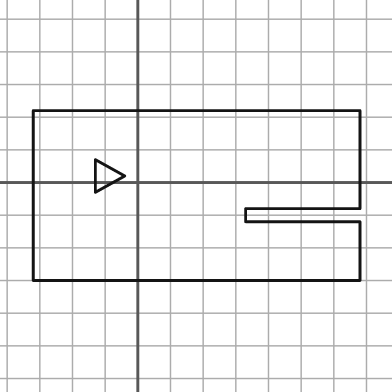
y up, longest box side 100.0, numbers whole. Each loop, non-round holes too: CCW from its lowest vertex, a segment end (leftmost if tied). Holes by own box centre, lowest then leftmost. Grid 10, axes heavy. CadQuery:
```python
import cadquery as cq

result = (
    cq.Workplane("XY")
    .moveTo(-32.0, -30.0)
    .lineTo(68.0, -30.0)
    .lineTo(68.0, -12.0)
    .lineTo(33.0, -12.0)
    .lineTo(33.0, -8.0)
    .lineTo(68.0, -8.0)
    .lineTo(68.0, 22.0)
    .lineTo(-32.0, 22.0)
    .close()
    .moveTo(-13.0, -3.0)
    .lineTo(-4.0, 2.0)
    .lineTo(-13.0, 7.0)
    .close()
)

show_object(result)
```